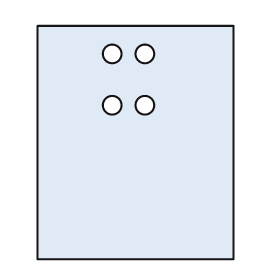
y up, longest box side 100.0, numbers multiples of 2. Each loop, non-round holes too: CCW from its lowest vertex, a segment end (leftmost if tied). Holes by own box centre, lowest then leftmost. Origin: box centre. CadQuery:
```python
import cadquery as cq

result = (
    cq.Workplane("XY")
    .moveTo(-42.0, -50.0)
    .lineTo(42.0, -50.0)
    .lineTo(42.0, 50.0)
    .lineTo(-42.0, 50.0)
    .close()
    .moveTo(-10.0, 16.0)
    .circle(4.0)
    .moveTo(4.0, 16.0)
    .circle(4.0)
    .moveTo(-10.0, 38.0)
    .circle(4.0)
    .moveTo(4.0, 38.0)
    .circle(4.0)
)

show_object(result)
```